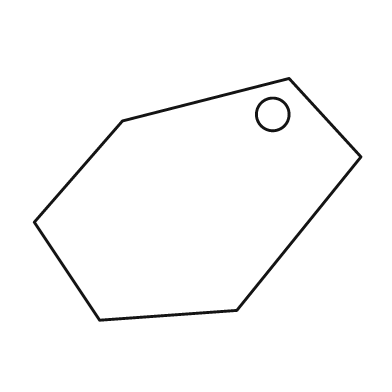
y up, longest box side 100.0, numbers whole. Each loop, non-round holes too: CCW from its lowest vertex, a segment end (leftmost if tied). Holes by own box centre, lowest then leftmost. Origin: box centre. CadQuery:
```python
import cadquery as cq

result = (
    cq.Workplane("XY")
    .moveTo(-30.0, -37.0)
    .lineTo(12.0, -34.0)
    .lineTo(50.0, 13.0)
    .lineTo(28.0, 37.0)
    .lineTo(-23.0, 24.0)
    .lineTo(-50.0, -7.0)
    .close()
    .moveTo(23.0, 26.0)
    .circle(5.0)
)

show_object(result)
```